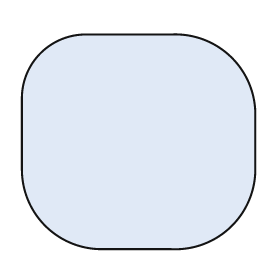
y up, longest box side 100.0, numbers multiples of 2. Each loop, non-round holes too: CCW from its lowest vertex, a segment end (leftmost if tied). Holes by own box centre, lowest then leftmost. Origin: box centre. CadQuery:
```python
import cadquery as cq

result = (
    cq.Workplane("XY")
    .moveTo(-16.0, -46.0)
    .lineTo(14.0, -46.0)
    .threePointArc((40.0, -36.0), (50.0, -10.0))
    .lineTo(50.0, 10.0)
    .threePointArc((40.0, 36.0), (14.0, 46.0))
    .lineTo(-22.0, 46.0)
    .threePointArc((-42.0, 38.0), (-50.0, 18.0))
    .lineTo(-50.0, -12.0)
    .threePointArc((-40.0, -36.0), (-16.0, -46.0))
    .close()
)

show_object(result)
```